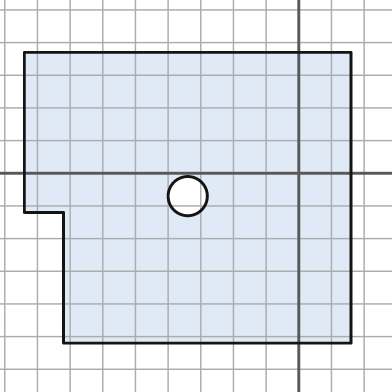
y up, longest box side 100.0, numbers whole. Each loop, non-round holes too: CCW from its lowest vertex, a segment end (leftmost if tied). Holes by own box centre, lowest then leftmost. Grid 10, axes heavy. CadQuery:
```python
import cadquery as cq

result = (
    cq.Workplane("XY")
    .moveTo(-72.0, -52.0)
    .lineTo(16.0, -52.0)
    .lineTo(16.0, 37.0)
    .lineTo(-84.0, 37.0)
    .lineTo(-84.0, -12.0)
    .lineTo(-72.0, -12.0)
    .close()
    .moveTo(-34.0, -7.0)
    .circle(6.0)
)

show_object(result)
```